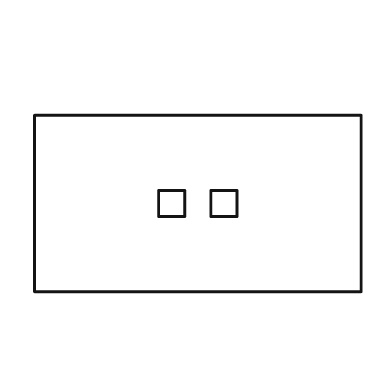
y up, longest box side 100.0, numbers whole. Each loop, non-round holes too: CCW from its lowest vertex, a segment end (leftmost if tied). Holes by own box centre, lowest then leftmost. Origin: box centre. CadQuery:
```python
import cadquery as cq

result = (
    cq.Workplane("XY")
    .moveTo(-50.0, -27.0)
    .lineTo(50.0, -27.0)
    .lineTo(50.0, 27.0)
    .lineTo(-50.0, 27.0)
    .close()
    .moveTo(-12.0, -4.0)
    .lineTo(-4.0, -4.0)
    .lineTo(-4.0, 4.0)
    .lineTo(-12.0, 4.0)
    .close()
    .moveTo(4.0, -4.0)
    .lineTo(12.0, -4.0)
    .lineTo(12.0, 4.0)
    .lineTo(4.0, 4.0)
    .close()
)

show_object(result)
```